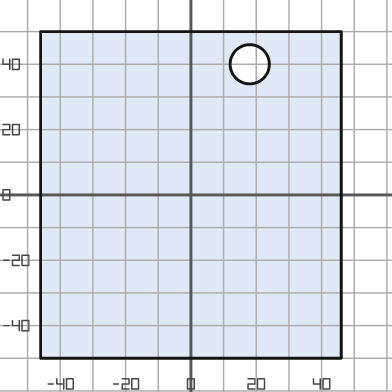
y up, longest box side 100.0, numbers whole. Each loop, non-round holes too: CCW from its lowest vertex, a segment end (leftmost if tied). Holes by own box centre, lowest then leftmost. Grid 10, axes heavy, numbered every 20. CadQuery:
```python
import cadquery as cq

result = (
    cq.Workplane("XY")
    .moveTo(-46.0, -50.0)
    .lineTo(46.0, -50.0)
    .lineTo(46.0, 50.0)
    .lineTo(-46.0, 50.0)
    .close()
    .moveTo(18.0, 40.0)
    .circle(6.0)
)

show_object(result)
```